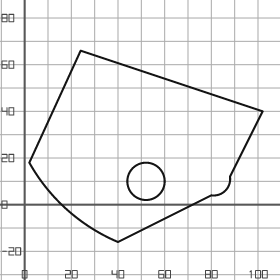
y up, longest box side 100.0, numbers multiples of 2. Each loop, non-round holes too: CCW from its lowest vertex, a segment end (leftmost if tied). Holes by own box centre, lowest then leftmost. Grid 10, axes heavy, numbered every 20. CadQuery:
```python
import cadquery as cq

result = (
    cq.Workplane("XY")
    .moveTo(40.0, -16.0)
    .lineTo(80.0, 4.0)
    .threePointArc((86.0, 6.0), (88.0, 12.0))
    .lineTo(102.0, 40.0)
    .lineTo(24.0, 66.0)
    .lineTo(2.0, 18.0)
    .threePointArc((18.0, -2.0), (40.0, -16.0))
    .close()
    .moveTo(52.0, 10.0)
    .circle(8.0)
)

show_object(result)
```